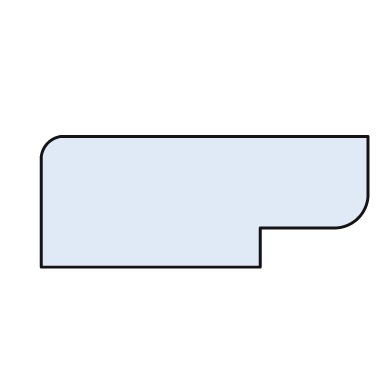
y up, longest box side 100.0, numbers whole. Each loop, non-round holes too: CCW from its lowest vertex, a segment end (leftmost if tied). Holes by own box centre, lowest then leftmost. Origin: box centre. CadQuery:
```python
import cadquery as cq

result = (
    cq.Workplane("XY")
    .moveTo(-50.0, -20.0)
    .lineTo(17.0, -20.0)
    .lineTo(17.0, -8.0)
    .lineTo(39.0, -8.0)
    .threePointArc((47.0, -5.0), (50.0, 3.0))
    .lineTo(50.0, 20.0)
    .lineTo(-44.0, 20.0)
    .threePointArc((-48.0, 18.0), (-50.0, 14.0))
    .close()
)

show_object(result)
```